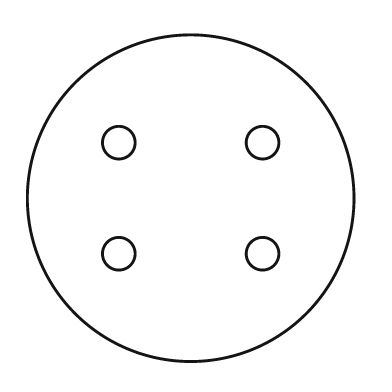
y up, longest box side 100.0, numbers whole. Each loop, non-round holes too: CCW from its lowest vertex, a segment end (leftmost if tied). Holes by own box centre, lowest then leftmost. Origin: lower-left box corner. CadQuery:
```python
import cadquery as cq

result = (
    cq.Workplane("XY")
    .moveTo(50.0, 50.0)
    .circle(50.0)
    .moveTo(28.0, 33.0)
    .circle(5.0)
    .moveTo(72.0, 33.0)
    .circle(5.0)
    .moveTo(28.0, 67.0)
    .circle(5.0)
    .moveTo(72.0, 67.0)
    .circle(5.0)
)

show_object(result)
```